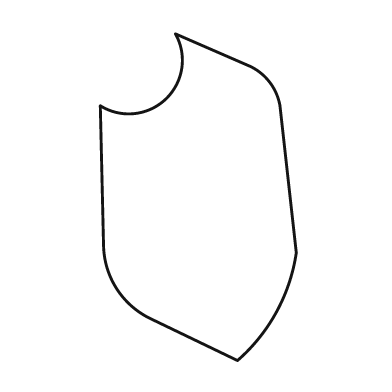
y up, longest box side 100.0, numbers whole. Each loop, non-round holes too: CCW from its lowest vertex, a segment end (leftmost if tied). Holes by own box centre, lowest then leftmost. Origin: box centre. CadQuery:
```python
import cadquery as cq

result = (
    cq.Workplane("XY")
    .moveTo(12.0, -50.0)
    .threePointArc((24.0, -35.0), (30.0, -17.0))
    .lineTo(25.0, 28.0)
    .threePointArc((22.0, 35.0), (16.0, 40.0))
    .lineTo(-7.0, 50.0)
    .threePointArc((-10.0, 30.0), (-30.0, 28.0))
    .lineTo(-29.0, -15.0)
    .threePointArc((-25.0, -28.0), (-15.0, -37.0))
    .close()
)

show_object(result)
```